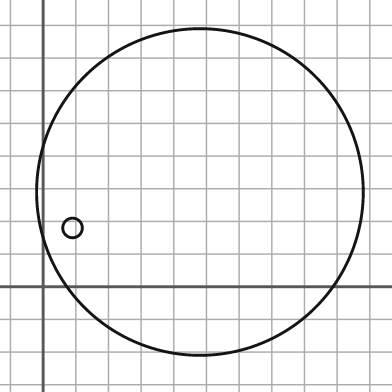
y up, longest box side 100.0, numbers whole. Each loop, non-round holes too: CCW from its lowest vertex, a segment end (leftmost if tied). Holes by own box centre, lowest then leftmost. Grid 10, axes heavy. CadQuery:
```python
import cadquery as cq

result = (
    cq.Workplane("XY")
    .moveTo(48.0, 29.0)
    .circle(50.0)
    .moveTo(9.0, 18.0)
    .circle(3.0)
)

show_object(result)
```